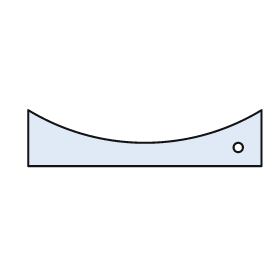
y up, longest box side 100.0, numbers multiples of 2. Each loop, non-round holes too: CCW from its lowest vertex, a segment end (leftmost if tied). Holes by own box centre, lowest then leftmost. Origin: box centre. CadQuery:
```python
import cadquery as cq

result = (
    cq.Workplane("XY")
    .moveTo(-50.0, -12.0)
    .lineTo(50.0, -12.0)
    .lineTo(50.0, 12.0)
    .threePointArc((0.0, -2.0), (-50.0, 12.0))
    .close()
    .moveTo(40.0, -4.0)
    .circle(2.0)
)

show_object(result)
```